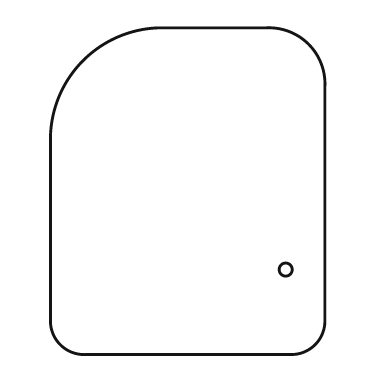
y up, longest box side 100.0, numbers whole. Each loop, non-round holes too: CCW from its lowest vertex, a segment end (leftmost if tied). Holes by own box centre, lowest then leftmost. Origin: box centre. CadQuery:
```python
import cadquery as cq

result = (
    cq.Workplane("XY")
    .moveTo(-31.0, -50.0)
    .lineTo(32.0, -50.0)
    .threePointArc((39.0, -47.0), (42.0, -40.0))
    .lineTo(42.0, 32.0)
    .threePointArc((37.0, 45.0), (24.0, 50.0))
    .lineTo(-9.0, 50.0)
    .threePointArc((-32.0, 40.0), (-42.0, 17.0))
    .lineTo(-42.0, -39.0)
    .threePointArc((-39.0, -47.0), (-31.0, -50.0))
    .close()
    .moveTo(30.0, -24.0)
    .circle(2.0)
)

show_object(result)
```